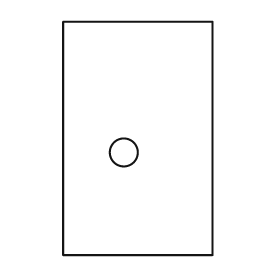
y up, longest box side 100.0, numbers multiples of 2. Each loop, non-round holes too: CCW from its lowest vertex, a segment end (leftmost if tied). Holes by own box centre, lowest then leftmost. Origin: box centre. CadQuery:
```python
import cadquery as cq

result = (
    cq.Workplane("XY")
    .moveTo(-32.0, -50.0)
    .lineTo(32.0, -50.0)
    .lineTo(32.0, 50.0)
    .lineTo(-32.0, 50.0)
    .close()
    .moveTo(-6.0, -6.0)
    .circle(6.0)
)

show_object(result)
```